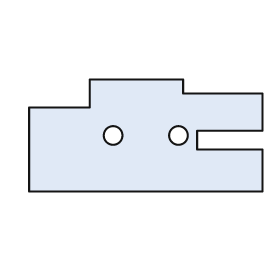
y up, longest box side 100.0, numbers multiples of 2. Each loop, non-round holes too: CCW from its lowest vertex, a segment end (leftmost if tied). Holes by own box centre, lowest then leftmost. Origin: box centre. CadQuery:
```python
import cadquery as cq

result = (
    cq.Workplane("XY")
    .moveTo(-50.0, -24.0)
    .lineTo(50.0, -24.0)
    .lineTo(50.0, -6.0)
    .lineTo(22.0, -6.0)
    .lineTo(22.0, 2.0)
    .lineTo(50.0, 2.0)
    .lineTo(50.0, 18.0)
    .lineTo(16.0, 18.0)
    .lineTo(16.0, 24.0)
    .lineTo(-24.0, 24.0)
    .lineTo(-24.0, 12.0)
    .lineTo(-50.0, 12.0)
    .close()
    .moveTo(-14.0, 0.0)
    .circle(4.0)
    .moveTo(14.0, 0.0)
    .circle(4.0)
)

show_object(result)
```